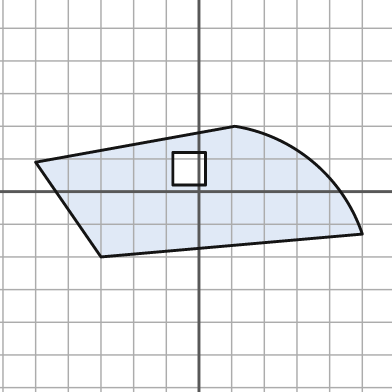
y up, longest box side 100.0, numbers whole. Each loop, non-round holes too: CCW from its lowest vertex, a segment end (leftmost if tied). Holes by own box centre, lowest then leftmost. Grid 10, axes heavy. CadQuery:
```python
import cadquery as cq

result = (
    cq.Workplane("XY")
    .moveTo(-30.0, -20.0)
    .lineTo(50.0, -13.0)
    .threePointArc((35.0, 9.0), (11.0, 20.0))
    .lineTo(-50.0, 9.0)
    .close()
    .moveTo(-8.0, 2.0)
    .lineTo(2.0, 2.0)
    .lineTo(2.0, 12.0)
    .lineTo(-8.0, 12.0)
    .close()
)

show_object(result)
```